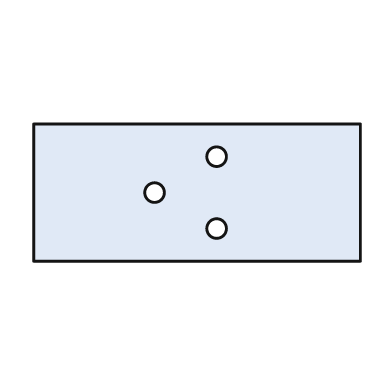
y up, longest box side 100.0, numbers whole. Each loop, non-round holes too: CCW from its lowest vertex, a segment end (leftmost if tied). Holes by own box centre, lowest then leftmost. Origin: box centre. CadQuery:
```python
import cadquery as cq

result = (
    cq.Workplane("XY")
    .moveTo(-50.0, -21.0)
    .lineTo(50.0, -21.0)
    .lineTo(50.0, 21.0)
    .lineTo(-50.0, 21.0)
    .close()
    .moveTo(6.0, -11.0)
    .circle(3.0)
    .moveTo(-13.0, 0.0)
    .circle(3.0)
    .moveTo(6.0, 11.0)
    .circle(3.0)
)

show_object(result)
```